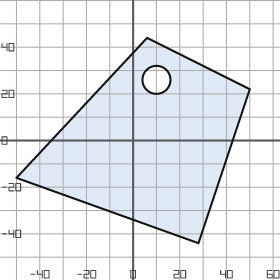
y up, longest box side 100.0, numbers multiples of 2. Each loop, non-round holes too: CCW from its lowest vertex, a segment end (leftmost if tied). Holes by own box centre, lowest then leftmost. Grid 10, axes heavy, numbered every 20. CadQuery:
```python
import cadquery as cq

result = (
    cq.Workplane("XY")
    .moveTo(28.0, -44.0)
    .lineTo(50.0, 22.0)
    .lineTo(6.0, 44.0)
    .lineTo(-50.0, -16.0)
    .close()
    .moveTo(10.0, 26.0)
    .circle(6.0)
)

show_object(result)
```